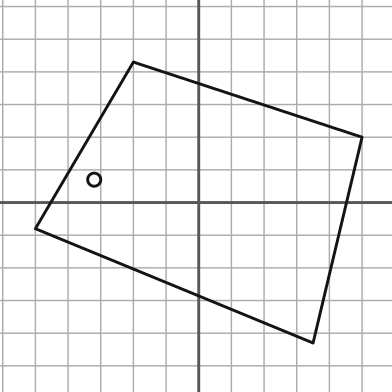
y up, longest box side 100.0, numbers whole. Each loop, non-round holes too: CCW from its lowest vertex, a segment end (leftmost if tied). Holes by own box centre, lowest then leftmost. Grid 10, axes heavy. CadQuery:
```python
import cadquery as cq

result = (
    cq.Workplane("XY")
    .moveTo(35.0, -43.0)
    .lineTo(50.0, 20.0)
    .lineTo(-20.0, 43.0)
    .lineTo(-50.0, -8.0)
    .close()
    .moveTo(-32.0, 7.0)
    .circle(2.0)
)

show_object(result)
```